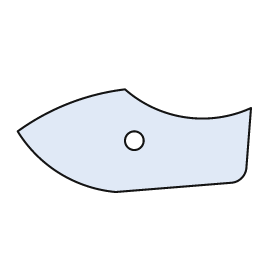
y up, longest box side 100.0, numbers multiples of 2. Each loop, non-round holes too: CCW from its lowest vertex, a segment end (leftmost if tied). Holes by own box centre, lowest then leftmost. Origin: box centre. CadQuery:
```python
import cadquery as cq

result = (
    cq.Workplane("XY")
    .moveTo(-8.0, -22.0)
    .lineTo(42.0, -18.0)
    .threePointArc((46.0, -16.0), (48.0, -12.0))
    .lineTo(50.0, 14.0)
    .threePointArc((22.0, 10.0), (-4.0, 22.0))
    .threePointArc((-28.0, 16.0), (-50.0, 4.0))
    .threePointArc((-32.0, -14.0), (-8.0, -22.0))
    .close()
    .moveTo(0.0, 0.0)
    .circle(4.0)
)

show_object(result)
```